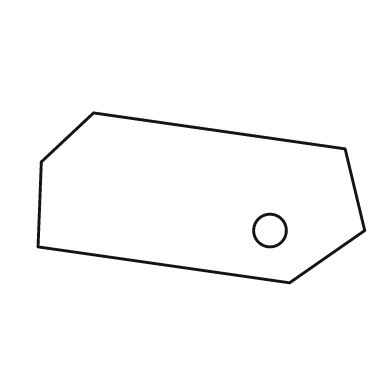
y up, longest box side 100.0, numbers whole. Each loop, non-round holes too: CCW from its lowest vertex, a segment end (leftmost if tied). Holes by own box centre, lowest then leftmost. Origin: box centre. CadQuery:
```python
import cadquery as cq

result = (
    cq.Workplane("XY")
    .moveTo(27.0, -26.0)
    .lineTo(50.0, -10.0)
    .lineTo(44.0, 15.0)
    .lineTo(-33.0, 26.0)
    .lineTo(-49.0, 11.0)
    .lineTo(-50.0, -15.0)
    .close()
    .moveTo(21.0, -10.0)
    .circle(5.0)
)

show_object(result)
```